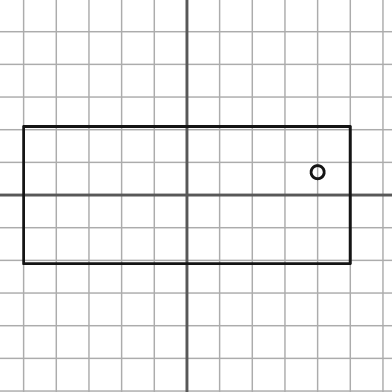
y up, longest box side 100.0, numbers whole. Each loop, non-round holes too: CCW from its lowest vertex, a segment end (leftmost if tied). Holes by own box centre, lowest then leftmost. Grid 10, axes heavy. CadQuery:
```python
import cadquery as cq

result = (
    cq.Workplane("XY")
    .moveTo(-50.0, -21.0)
    .lineTo(50.0, -21.0)
    .lineTo(50.0, 21.0)
    .lineTo(-50.0, 21.0)
    .close()
    .moveTo(40.0, 7.0)
    .circle(2.0)
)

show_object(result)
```